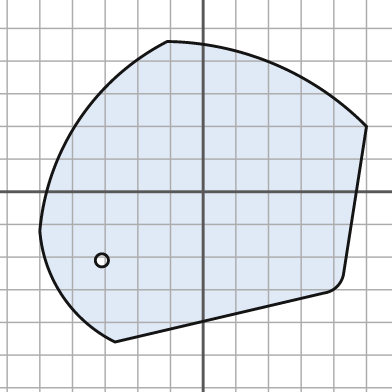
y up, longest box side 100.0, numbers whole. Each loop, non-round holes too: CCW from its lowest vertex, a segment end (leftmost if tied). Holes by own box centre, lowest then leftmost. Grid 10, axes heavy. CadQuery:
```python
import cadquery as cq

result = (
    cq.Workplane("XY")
    .moveTo(-27.0, -46.0)
    .lineTo(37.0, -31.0)
    .threePointArc((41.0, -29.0), (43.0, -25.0))
    .lineTo(50.0, 20.0)
    .threePointArc((22.0, 39.0), (-11.0, 46.0))
    .threePointArc((-38.0, 22.0), (-50.0, -12.0))
    .threePointArc((-43.0, -32.0), (-27.0, -46.0))
    .close()
    .moveTo(-31.0, -21.0)
    .circle(2.0)
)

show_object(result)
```